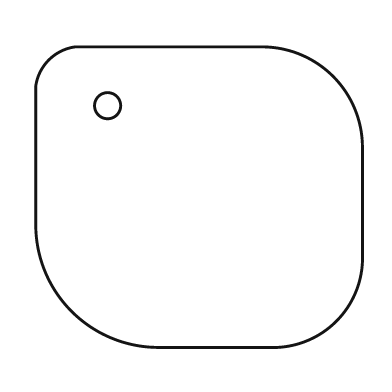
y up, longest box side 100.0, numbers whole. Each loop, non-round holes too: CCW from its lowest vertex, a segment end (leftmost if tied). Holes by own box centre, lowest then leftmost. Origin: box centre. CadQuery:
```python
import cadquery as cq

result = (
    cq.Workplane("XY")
    .moveTo(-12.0, -46.0)
    .lineTo(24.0, -46.0)
    .threePointArc((42.0, -38.0), (50.0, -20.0))
    .lineTo(50.0, 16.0)
    .threePointArc((41.0, 37.0), (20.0, 46.0))
    .lineTo(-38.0, 46.0)
    .threePointArc((-46.0, 42.0), (-50.0, 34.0))
    .lineTo(-50.0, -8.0)
    .threePointArc((-39.0, -35.0), (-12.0, -46.0))
    .close()
    .moveTo(-28.0, 28.0)
    .circle(4.0)
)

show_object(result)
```